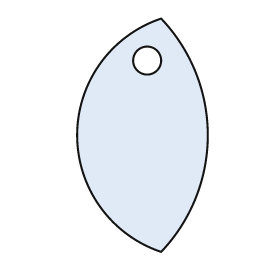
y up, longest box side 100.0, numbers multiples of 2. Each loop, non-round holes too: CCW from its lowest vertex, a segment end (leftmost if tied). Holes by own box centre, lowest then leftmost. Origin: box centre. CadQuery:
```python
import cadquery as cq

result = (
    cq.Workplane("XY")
    .moveTo(8.0, -50.0)
    .threePointArc((28.0, 0.0), (8.0, 50.0))
    .threePointArc((-28.0, 0.0), (8.0, -50.0))
    .close()
    .moveTo(2.0, 32.0)
    .circle(6.0)
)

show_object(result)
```